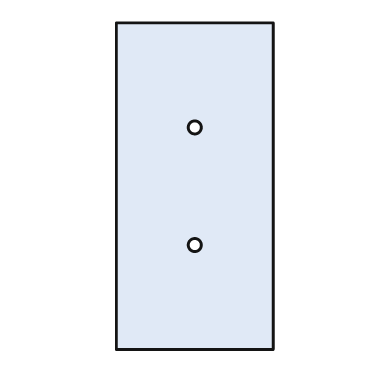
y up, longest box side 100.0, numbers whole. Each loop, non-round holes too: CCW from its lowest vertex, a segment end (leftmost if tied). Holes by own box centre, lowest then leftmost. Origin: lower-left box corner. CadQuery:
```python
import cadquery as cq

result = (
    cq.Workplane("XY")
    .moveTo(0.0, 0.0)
    .lineTo(48.0, 0.0)
    .lineTo(48.0, 100.0)
    .lineTo(0.0, 100.0)
    .close()
    .moveTo(24.0, 32.0)
    .circle(2.0)
    .moveTo(24.0, 68.0)
    .circle(2.0)
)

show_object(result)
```